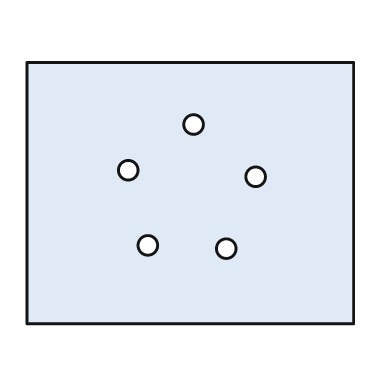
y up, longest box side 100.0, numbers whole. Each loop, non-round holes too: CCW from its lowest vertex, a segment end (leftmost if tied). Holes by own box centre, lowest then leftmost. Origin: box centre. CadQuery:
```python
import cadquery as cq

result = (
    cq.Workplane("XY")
    .moveTo(-50.0, -40.0)
    .lineTo(50.0, -40.0)
    .lineTo(50.0, 40.0)
    .lineTo(-50.0, 40.0)
    .close()
    .moveTo(11.0, -17.0)
    .circle(3.0)
    .moveTo(-13.0, -16.0)
    .circle(3.0)
    .moveTo(20.0, 5.0)
    .circle(3.0)
    .moveTo(-19.0, 7.0)
    .circle(3.0)
    .moveTo(1.0, 21.0)
    .circle(3.0)
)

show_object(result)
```